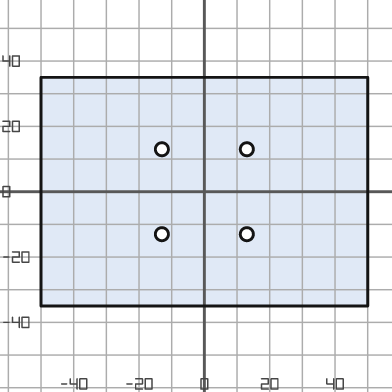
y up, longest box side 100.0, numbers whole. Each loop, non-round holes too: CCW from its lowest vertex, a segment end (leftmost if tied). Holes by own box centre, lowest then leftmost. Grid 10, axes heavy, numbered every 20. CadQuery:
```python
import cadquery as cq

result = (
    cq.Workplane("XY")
    .moveTo(-50.0, -35.0)
    .lineTo(50.0, -35.0)
    .lineTo(50.0, 35.0)
    .lineTo(-50.0, 35.0)
    .close()
    .moveTo(-13.0, -13.0)
    .circle(2.0)
    .moveTo(13.0, -13.0)
    .circle(2.0)
    .moveTo(-13.0, 13.0)
    .circle(2.0)
    .moveTo(13.0, 13.0)
    .circle(2.0)
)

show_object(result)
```